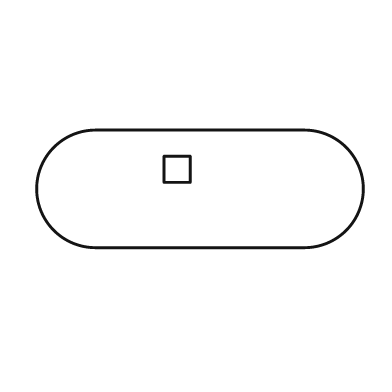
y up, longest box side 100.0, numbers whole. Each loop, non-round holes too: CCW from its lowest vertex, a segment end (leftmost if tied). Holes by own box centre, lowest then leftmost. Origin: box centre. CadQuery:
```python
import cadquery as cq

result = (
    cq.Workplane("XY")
    .moveTo(-32.0, -18.0)
    .lineTo(32.0, -18.0)
    .threePointArc((50.0, 0.0), (32.0, 18.0))
    .lineTo(-32.0, 18.0)
    .threePointArc((-50.0, 0.0), (-32.0, -18.0))
    .close()
    .moveTo(-11.0, 2.0)
    .lineTo(-3.0, 2.0)
    .lineTo(-3.0, 10.0)
    .lineTo(-11.0, 10.0)
    .close()
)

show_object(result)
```